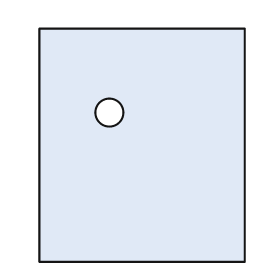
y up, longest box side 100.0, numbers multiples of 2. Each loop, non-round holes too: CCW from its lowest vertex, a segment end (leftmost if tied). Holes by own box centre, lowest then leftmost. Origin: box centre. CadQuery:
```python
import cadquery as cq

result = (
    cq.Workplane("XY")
    .moveTo(-44.0, -50.0)
    .lineTo(44.0, -50.0)
    .lineTo(44.0, 50.0)
    .lineTo(-44.0, 50.0)
    .close()
    .moveTo(-14.0, 14.0)
    .circle(6.0)
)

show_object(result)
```